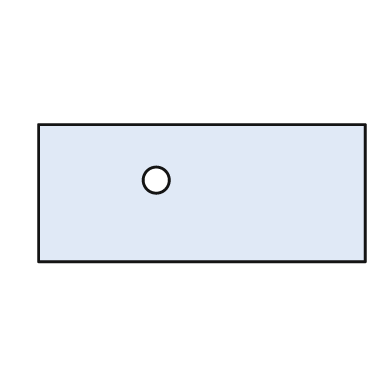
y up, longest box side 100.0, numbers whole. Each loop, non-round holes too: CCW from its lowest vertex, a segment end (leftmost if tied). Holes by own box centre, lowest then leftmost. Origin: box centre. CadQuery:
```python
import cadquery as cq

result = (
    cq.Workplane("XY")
    .moveTo(-50.0, -21.0)
    .lineTo(50.0, -21.0)
    .lineTo(50.0, 21.0)
    .lineTo(-50.0, 21.0)
    .close()
    .moveTo(-14.0, 4.0)
    .circle(4.0)
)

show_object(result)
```